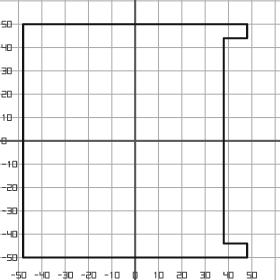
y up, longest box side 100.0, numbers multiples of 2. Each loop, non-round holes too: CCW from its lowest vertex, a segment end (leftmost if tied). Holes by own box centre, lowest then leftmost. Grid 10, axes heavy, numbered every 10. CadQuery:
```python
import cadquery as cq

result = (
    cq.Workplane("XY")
    .moveTo(-48.0, -50.0)
    .lineTo(48.0, -50.0)
    .lineTo(48.0, -44.0)
    .lineTo(38.0, -44.0)
    .lineTo(38.0, 44.0)
    .lineTo(48.0, 44.0)
    .lineTo(48.0, 50.0)
    .lineTo(-48.0, 50.0)
    .close()
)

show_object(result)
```